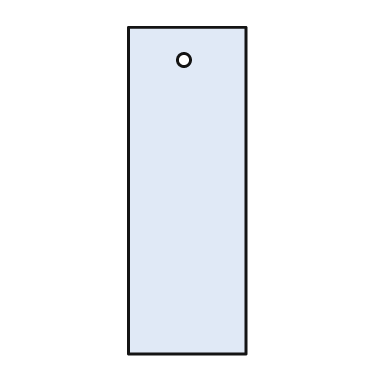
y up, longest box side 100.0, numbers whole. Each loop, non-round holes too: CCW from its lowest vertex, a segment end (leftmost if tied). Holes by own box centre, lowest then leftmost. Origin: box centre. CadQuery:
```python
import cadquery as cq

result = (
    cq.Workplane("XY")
    .moveTo(-18.0, -50.0)
    .lineTo(18.0, -50.0)
    .lineTo(18.0, 50.0)
    .lineTo(-18.0, 50.0)
    .close()
    .moveTo(-1.0, 40.0)
    .circle(2.0)
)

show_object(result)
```